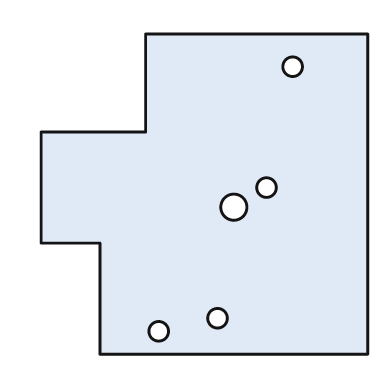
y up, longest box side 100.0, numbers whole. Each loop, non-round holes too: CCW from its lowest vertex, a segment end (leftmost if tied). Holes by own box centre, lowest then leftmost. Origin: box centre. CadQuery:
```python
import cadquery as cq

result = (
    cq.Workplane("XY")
    .moveTo(-32.0, -49.0)
    .lineTo(50.0, -49.0)
    .lineTo(50.0, 49.0)
    .lineTo(-18.0, 49.0)
    .lineTo(-18.0, 19.0)
    .lineTo(-50.0, 19.0)
    .lineTo(-50.0, -15.0)
    .lineTo(-32.0, -15.0)
    .close()
    .moveTo(-14.0, -42.0)
    .circle(3.0)
    .moveTo(4.0, -38.0)
    .circle(3.0)
    .moveTo(9.0, -4.0)
    .circle(4.0)
    .moveTo(19.0, 2.0)
    .circle(3.0)
    .moveTo(27.0, 39.0)
    .circle(3.0)
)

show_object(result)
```